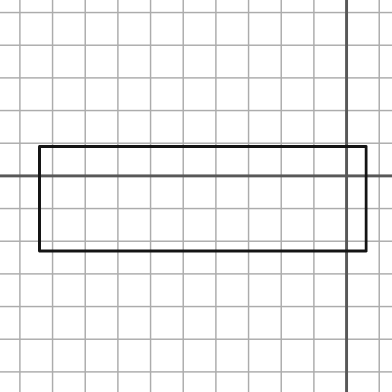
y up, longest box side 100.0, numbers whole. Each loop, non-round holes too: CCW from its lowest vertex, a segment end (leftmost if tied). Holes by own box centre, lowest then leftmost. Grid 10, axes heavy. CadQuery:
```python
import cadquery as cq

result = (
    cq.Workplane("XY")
    .moveTo(-94.0, -23.0)
    .lineTo(6.0, -23.0)
    .lineTo(6.0, 9.0)
    .lineTo(-94.0, 9.0)
    .close()
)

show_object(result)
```